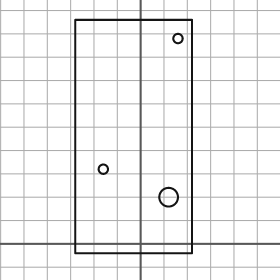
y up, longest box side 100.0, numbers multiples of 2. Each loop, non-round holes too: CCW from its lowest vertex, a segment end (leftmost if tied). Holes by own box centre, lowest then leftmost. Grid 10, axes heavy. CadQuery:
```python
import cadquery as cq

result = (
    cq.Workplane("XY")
    .moveTo(-28.0, -4.0)
    .lineTo(22.0, -4.0)
    .lineTo(22.0, 96.0)
    .lineTo(-28.0, 96.0)
    .close()
    .moveTo(12.0, 20.0)
    .circle(4.0)
    .moveTo(-16.0, 32.0)
    .circle(2.0)
    .moveTo(16.0, 88.0)
    .circle(2.0)
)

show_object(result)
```